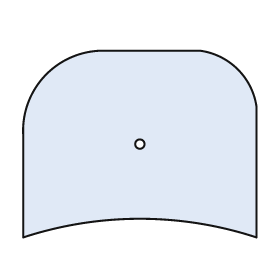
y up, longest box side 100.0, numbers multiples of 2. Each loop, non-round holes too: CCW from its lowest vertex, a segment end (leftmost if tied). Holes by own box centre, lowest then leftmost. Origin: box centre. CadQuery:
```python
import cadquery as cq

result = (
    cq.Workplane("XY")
    .moveTo(-50.0, -40.0)
    .threePointArc((0.0, -32.0), (50.0, -40.0))
    .lineTo(50.0, 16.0)
    .threePointArc((42.0, 32.0), (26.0, 40.0))
    .lineTo(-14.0, 40.0)
    .threePointArc((-40.0, 30.0), (-50.0, 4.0))
    .close()
    .moveTo(0.0, 0.0)
    .circle(2.0)
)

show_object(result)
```